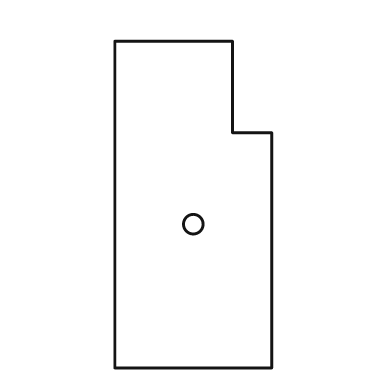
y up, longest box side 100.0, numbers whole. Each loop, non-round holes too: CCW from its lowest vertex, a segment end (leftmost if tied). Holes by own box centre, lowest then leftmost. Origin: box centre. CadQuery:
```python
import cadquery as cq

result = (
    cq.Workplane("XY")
    .moveTo(-24.0, -50.0)
    .lineTo(24.0, -50.0)
    .lineTo(24.0, 22.0)
    .lineTo(12.0, 22.0)
    .lineTo(12.0, 50.0)
    .lineTo(-24.0, 50.0)
    .close()
    .moveTo(0.0, -6.0)
    .circle(3.0)
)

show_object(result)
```